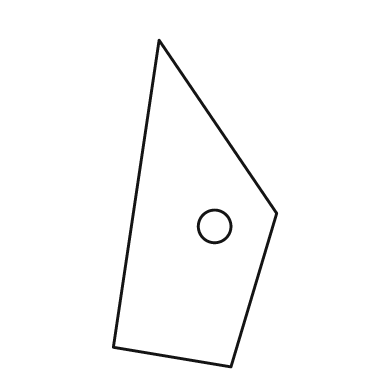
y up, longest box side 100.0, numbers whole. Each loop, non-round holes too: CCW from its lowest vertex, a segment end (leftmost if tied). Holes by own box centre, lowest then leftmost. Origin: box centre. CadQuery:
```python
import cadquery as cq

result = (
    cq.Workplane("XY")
    .moveTo(11.0, -50.0)
    .lineTo(25.0, -3.0)
    .lineTo(-11.0, 50.0)
    .lineTo(-25.0, -44.0)
    .close()
    .moveTo(6.0, -7.0)
    .circle(5.0)
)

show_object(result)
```